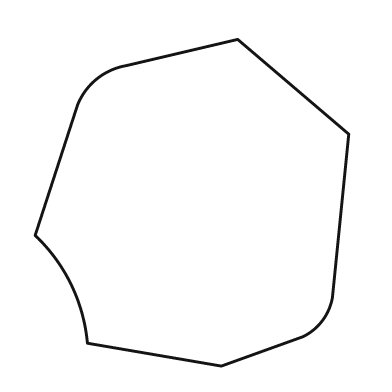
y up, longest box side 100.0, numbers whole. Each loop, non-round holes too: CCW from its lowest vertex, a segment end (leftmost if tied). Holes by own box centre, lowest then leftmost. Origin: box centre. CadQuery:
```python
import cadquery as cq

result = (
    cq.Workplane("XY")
    .moveTo(9.0, -50.0)
    .lineTo(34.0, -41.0)
    .threePointArc((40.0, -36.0), (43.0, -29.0))
    .lineTo(48.0, 21.0)
    .lineTo(14.0, 50.0)
    .lineTo(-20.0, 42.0)
    .threePointArc((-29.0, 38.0), (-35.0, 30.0))
    .lineTo(-48.0, -10.0)
    .threePointArc((-37.0, -25.0), (-32.0, -43.0))
    .close()
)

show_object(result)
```